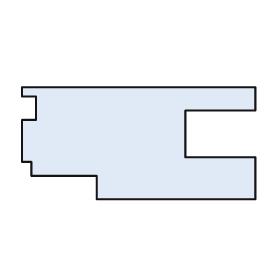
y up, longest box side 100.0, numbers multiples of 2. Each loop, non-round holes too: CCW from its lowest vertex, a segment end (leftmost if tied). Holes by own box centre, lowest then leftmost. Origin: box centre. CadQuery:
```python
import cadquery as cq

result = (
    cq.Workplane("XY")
    .moveTo(-18.0, -24.0)
    .lineTo(50.0, -24.0)
    .lineTo(50.0, -6.0)
    .lineTo(20.0, -6.0)
    .lineTo(20.0, 14.0)
    .lineTo(50.0, 14.0)
    .lineTo(50.0, 24.0)
    .lineTo(-50.0, 24.0)
    .lineTo(-50.0, 20.0)
    .lineTo(-44.0, 20.0)
    .lineTo(-44.0, 10.0)
    .lineTo(-50.0, 10.0)
    .lineTo(-50.0, -8.0)
    .lineTo(-46.0, -8.0)
    .lineTo(-46.0, -14.0)
    .lineTo(-18.0, -14.0)
    .close()
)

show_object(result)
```